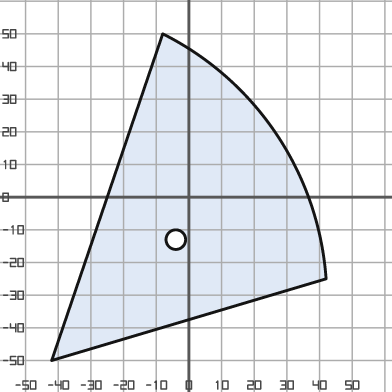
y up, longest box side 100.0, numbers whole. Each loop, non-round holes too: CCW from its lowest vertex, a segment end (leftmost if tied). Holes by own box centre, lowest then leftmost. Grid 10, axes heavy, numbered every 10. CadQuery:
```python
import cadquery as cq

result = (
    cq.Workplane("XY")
    .moveTo(-42.0, -50.0)
    .lineTo(42.0, -25.0)
    .threePointArc((27.0, 19.0), (-8.0, 50.0))
    .close()
    .moveTo(-4.0, -13.0)
    .circle(3.0)
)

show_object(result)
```